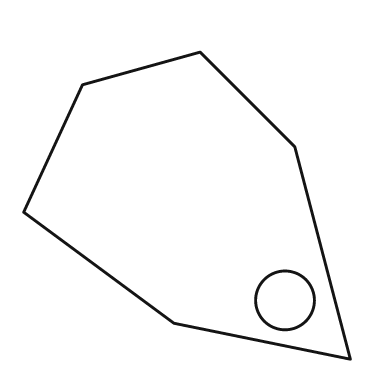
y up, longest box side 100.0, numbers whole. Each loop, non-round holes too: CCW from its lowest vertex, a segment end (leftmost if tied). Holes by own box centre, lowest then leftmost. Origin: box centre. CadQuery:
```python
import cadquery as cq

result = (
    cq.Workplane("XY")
    .moveTo(50.0, -47.0)
    .lineTo(33.0, 18.0)
    .lineTo(4.0, 47.0)
    .lineTo(-32.0, 37.0)
    .lineTo(-50.0, -2.0)
    .lineTo(-4.0, -36.0)
    .close()
    .moveTo(30.0, -29.0)
    .circle(9.0)
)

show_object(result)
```